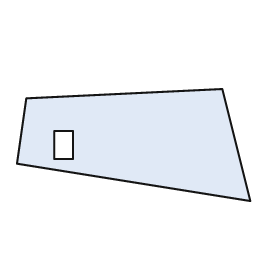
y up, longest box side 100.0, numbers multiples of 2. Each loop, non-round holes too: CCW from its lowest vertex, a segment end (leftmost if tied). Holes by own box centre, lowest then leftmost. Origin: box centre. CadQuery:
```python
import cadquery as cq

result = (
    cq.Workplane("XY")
    .moveTo(50.0, -24.0)
    .lineTo(38.0, 24.0)
    .lineTo(-46.0, 20.0)
    .lineTo(-50.0, -8.0)
    .close()
    .moveTo(-34.0, -6.0)
    .lineTo(-26.0, -6.0)
    .lineTo(-26.0, 6.0)
    .lineTo(-34.0, 6.0)
    .close()
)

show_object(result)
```